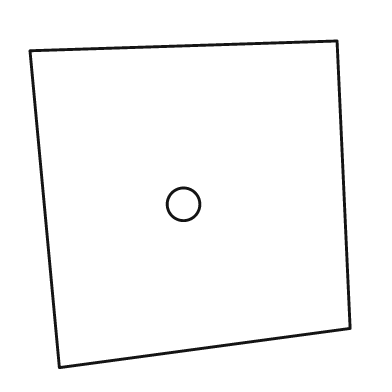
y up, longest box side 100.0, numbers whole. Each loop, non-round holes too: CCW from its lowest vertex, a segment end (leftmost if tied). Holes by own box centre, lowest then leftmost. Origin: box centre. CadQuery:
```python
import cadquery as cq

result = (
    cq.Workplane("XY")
    .moveTo(-40.0, -50.0)
    .lineTo(49.0, -38.0)
    .lineTo(45.0, 50.0)
    .lineTo(-49.0, 47.0)
    .close()
    .moveTo(-2.0, 0.0)
    .circle(5.0)
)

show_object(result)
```